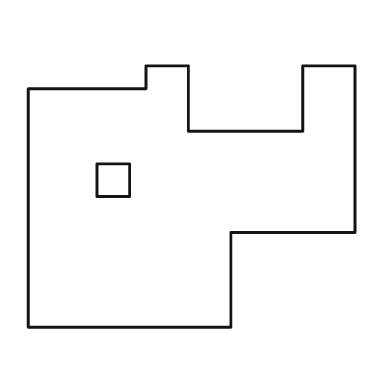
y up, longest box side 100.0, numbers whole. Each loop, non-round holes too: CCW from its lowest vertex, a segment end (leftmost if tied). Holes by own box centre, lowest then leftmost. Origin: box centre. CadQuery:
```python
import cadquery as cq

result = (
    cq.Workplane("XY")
    .moveTo(-50.0, -40.0)
    .lineTo(12.0, -40.0)
    .lineTo(12.0, -11.0)
    .lineTo(50.0, -11.0)
    .lineTo(50.0, 40.0)
    .lineTo(34.0, 40.0)
    .lineTo(34.0, 20.0)
    .lineTo(-1.0, 20.0)
    .lineTo(-1.0, 40.0)
    .lineTo(-14.0, 40.0)
    .lineTo(-14.0, 33.0)
    .lineTo(-50.0, 33.0)
    .close()
    .moveTo(-29.0, 0.0)
    .lineTo(-19.0, 0.0)
    .lineTo(-19.0, 10.0)
    .lineTo(-29.0, 10.0)
    .close()
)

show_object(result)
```